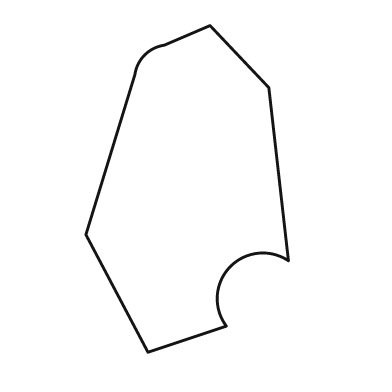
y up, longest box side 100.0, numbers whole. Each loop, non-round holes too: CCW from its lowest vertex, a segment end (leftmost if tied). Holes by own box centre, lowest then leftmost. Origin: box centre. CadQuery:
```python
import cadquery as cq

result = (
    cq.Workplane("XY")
    .moveTo(-12.0, -50.0)
    .lineTo(12.0, -42.0)
    .threePointArc((13.0, -24.0), (31.0, -22.0))
    .lineTo(25.0, 31.0)
    .lineTo(7.0, 50.0)
    .lineTo(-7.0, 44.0)
    .threePointArc((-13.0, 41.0), (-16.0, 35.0))
    .lineTo(-31.0, -14.0)
    .close()
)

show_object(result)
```